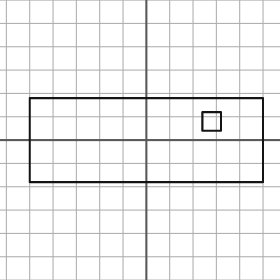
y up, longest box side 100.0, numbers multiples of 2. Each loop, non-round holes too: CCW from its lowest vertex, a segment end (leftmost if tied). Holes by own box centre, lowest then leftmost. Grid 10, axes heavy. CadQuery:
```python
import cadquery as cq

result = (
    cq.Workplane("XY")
    .moveTo(-50.0, -18.0)
    .lineTo(50.0, -18.0)
    .lineTo(50.0, 18.0)
    .lineTo(-50.0, 18.0)
    .close()
    .moveTo(24.0, 4.0)
    .lineTo(32.0, 4.0)
    .lineTo(32.0, 12.0)
    .lineTo(24.0, 12.0)
    .close()
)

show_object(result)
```